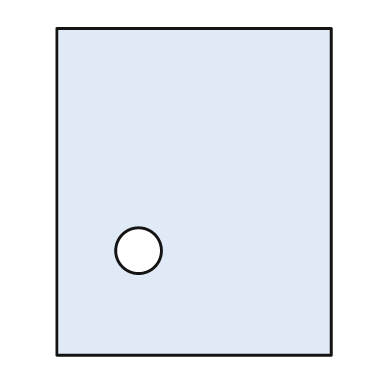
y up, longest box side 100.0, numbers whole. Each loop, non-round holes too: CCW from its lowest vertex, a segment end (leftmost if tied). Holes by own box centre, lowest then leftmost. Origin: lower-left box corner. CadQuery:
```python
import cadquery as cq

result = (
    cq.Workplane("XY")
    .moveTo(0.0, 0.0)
    .lineTo(84.0, 0.0)
    .lineTo(84.0, 100.0)
    .lineTo(0.0, 100.0)
    .close()
    .moveTo(25.0, 32.0)
    .circle(7.0)
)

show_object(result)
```